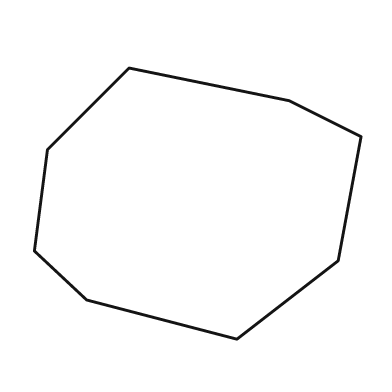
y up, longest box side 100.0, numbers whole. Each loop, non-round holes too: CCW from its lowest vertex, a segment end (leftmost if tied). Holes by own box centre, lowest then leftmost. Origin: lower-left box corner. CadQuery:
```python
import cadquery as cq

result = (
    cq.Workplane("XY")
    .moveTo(62.0, 0.0)
    .lineTo(93.0, 24.0)
    .lineTo(100.0, 62.0)
    .lineTo(78.0, 73.0)
    .lineTo(29.0, 83.0)
    .lineTo(4.0, 58.0)
    .lineTo(0.0, 27.0)
    .lineTo(16.0, 12.0)
    .close()
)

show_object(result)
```